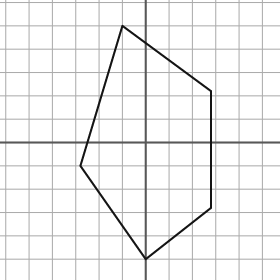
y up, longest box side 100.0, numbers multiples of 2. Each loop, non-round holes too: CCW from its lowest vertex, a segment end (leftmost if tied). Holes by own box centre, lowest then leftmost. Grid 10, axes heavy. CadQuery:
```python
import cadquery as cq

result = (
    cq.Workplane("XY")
    .moveTo(0.0, -50.0)
    .lineTo(28.0, -28.0)
    .lineTo(28.0, 22.0)
    .lineTo(-10.0, 50.0)
    .lineTo(-28.0, -10.0)
    .close()
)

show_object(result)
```